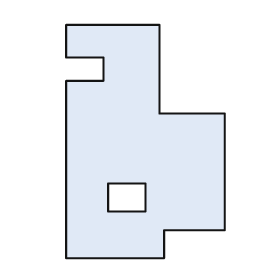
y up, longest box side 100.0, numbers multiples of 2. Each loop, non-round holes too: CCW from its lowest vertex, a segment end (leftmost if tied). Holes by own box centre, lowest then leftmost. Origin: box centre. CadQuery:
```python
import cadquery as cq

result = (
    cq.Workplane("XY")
    .moveTo(-34.0, -50.0)
    .lineTo(8.0, -50.0)
    .lineTo(8.0, -38.0)
    .lineTo(34.0, -38.0)
    .lineTo(34.0, 12.0)
    .lineTo(6.0, 12.0)
    .lineTo(6.0, 50.0)
    .lineTo(-34.0, 50.0)
    .lineTo(-34.0, 36.0)
    .lineTo(-18.0, 36.0)
    .lineTo(-18.0, 26.0)
    .lineTo(-34.0, 26.0)
    .close()
    .moveTo(-16.0, -30.0)
    .lineTo(0.0, -30.0)
    .lineTo(0.0, -18.0)
    .lineTo(-16.0, -18.0)
    .close()
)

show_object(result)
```